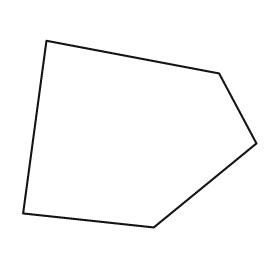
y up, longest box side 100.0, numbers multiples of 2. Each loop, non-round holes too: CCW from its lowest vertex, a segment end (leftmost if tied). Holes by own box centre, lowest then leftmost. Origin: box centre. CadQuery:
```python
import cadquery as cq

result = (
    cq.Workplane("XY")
    .moveTo(6.0, -40.0)
    .lineTo(50.0, -4.0)
    .lineTo(34.0, 26.0)
    .lineTo(-40.0, 40.0)
    .lineTo(-50.0, -34.0)
    .close()
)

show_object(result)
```